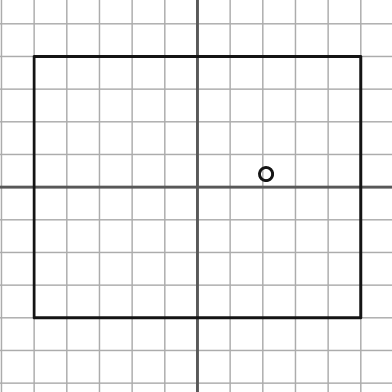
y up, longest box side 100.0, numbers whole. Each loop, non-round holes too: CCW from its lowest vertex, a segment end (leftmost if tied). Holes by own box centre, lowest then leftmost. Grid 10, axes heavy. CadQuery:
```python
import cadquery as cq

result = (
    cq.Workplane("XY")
    .moveTo(-50.0, -40.0)
    .lineTo(50.0, -40.0)
    .lineTo(50.0, 40.0)
    .lineTo(-50.0, 40.0)
    .close()
    .moveTo(21.0, 4.0)
    .circle(2.0)
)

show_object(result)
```